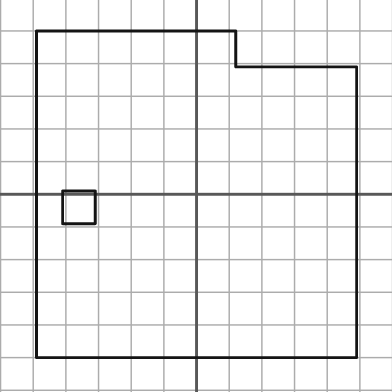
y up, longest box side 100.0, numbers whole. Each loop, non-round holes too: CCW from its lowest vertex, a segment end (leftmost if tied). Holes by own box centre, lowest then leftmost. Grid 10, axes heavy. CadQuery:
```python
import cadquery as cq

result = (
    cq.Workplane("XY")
    .moveTo(-49.0, -50.0)
    .lineTo(49.0, -50.0)
    .lineTo(49.0, 39.0)
    .lineTo(12.0, 39.0)
    .lineTo(12.0, 50.0)
    .lineTo(-49.0, 50.0)
    .close()
    .moveTo(-41.0, -9.0)
    .lineTo(-31.0, -9.0)
    .lineTo(-31.0, 1.0)
    .lineTo(-41.0, 1.0)
    .close()
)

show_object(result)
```